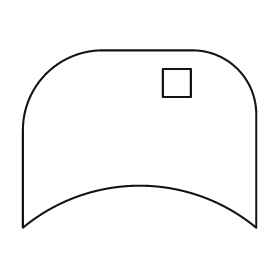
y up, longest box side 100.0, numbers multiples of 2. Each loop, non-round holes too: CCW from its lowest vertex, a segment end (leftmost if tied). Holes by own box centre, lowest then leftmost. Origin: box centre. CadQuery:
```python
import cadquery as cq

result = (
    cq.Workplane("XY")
    .moveTo(-50.0, -38.0)
    .threePointArc((0.0, -20.0), (50.0, -38.0))
    .lineTo(50.0, 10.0)
    .threePointArc((42.0, 30.0), (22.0, 38.0))
    .lineTo(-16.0, 38.0)
    .threePointArc((-40.0, 28.0), (-50.0, 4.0))
    .close()
    .moveTo(10.0, 18.0)
    .lineTo(22.0, 18.0)
    .lineTo(22.0, 30.0)
    .lineTo(10.0, 30.0)
    .close()
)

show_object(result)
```